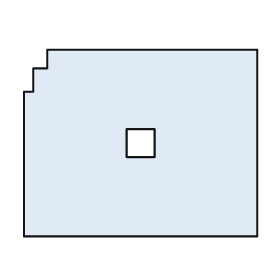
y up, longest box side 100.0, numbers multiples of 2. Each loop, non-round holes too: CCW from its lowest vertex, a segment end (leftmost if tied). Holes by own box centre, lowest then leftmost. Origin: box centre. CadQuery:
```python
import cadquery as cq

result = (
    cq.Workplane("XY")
    .moveTo(-50.0, -40.0)
    .lineTo(50.0, -40.0)
    .lineTo(50.0, 40.0)
    .lineTo(-40.0, 40.0)
    .lineTo(-40.0, 32.0)
    .lineTo(-46.0, 32.0)
    .lineTo(-46.0, 22.0)
    .lineTo(-50.0, 22.0)
    .close()
    .moveTo(-6.0, -6.0)
    .lineTo(6.0, -6.0)
    .lineTo(6.0, 6.0)
    .lineTo(-6.0, 6.0)
    .close()
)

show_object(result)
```